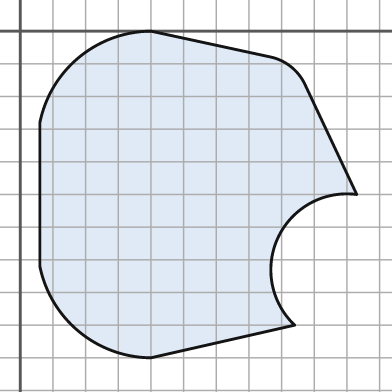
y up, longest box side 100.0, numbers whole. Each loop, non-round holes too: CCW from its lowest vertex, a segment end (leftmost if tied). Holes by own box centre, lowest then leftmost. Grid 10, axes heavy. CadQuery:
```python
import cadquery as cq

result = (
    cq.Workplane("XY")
    .moveTo(40.0, -100.0)
    .lineTo(84.0, -90.0)
    .threePointArc((79.0, -63.0), (103.0, -50.0))
    .lineTo(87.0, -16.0)
    .threePointArc((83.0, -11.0), (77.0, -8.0))
    .lineTo(40.0, 0.0)
    .threePointArc((18.0, -8.0), (6.0, -28.0))
    .lineTo(6.0, -72.0)
    .threePointArc((18.0, -92.0), (40.0, -100.0))
    .close()
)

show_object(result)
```